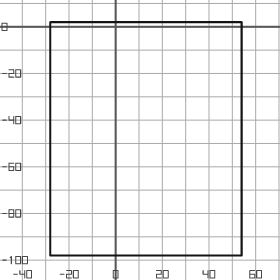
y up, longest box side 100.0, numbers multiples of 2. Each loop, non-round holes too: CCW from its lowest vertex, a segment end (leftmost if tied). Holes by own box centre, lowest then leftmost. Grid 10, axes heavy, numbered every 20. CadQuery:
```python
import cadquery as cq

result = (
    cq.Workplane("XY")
    .moveTo(-28.0, -98.0)
    .lineTo(54.0, -98.0)
    .lineTo(54.0, 2.0)
    .lineTo(-28.0, 2.0)
    .close()
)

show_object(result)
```